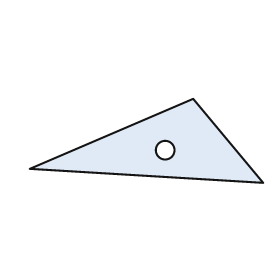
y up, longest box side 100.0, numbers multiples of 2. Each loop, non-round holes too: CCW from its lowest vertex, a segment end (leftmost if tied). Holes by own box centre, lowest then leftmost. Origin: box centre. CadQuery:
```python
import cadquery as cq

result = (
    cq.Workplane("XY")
    .moveTo(50.0, -18.0)
    .lineTo(20.0, 18.0)
    .lineTo(-50.0, -12.0)
    .close()
    .moveTo(8.0, -4.0)
    .circle(4.0)
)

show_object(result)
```